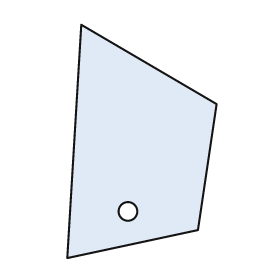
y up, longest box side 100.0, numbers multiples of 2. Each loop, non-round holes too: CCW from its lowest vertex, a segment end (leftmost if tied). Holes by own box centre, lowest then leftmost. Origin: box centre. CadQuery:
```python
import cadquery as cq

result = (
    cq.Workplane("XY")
    .moveTo(-32.0, -50.0)
    .lineTo(24.0, -38.0)
    .lineTo(32.0, 16.0)
    .lineTo(-26.0, 50.0)
    .close()
    .moveTo(-6.0, -30.0)
    .circle(4.0)
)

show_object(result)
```